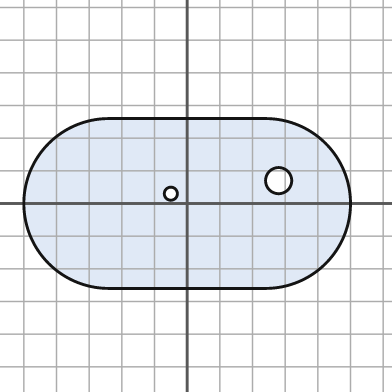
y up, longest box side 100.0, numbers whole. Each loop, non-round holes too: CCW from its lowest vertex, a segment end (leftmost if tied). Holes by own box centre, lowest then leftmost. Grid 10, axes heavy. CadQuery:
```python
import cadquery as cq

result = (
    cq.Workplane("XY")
    .moveTo(-24.0, -26.0)
    .lineTo(24.0, -26.0)
    .threePointArc((50.0, 0.0), (24.0, 26.0))
    .lineTo(-24.0, 26.0)
    .threePointArc((-50.0, 0.0), (-24.0, -26.0))
    .close()
    .moveTo(-5.0, 3.0)
    .circle(2.0)
    .moveTo(28.0, 7.0)
    .circle(4.0)
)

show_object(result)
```